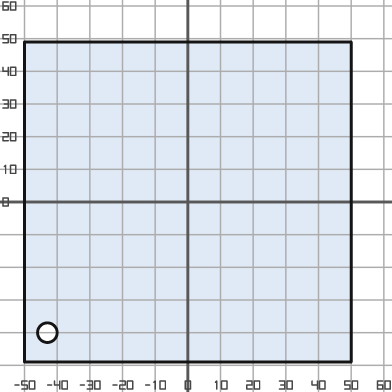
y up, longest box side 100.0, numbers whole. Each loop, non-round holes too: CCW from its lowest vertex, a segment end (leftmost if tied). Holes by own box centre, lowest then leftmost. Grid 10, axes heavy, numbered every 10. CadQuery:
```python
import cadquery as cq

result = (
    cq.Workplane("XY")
    .moveTo(-50.0, -49.0)
    .lineTo(50.0, -49.0)
    .lineTo(50.0, 49.0)
    .lineTo(-50.0, 49.0)
    .close()
    .moveTo(-43.0, -40.0)
    .circle(3.0)
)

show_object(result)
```